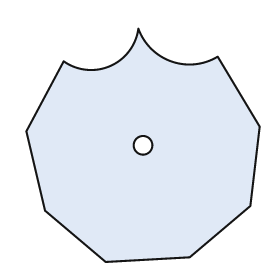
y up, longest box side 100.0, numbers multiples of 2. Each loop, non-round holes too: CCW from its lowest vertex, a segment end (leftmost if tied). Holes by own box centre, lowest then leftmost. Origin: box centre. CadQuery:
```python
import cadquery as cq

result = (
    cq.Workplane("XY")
    .moveTo(-16.0, -50.0)
    .lineTo(20.0, -48.0)
    .lineTo(46.0, -26.0)
    .lineTo(50.0, 8.0)
    .lineTo(32.0, 38.0)
    .threePointArc((12.0, 36.0), (-2.0, 50.0))
    .threePointArc((-14.0, 34.0), (-34.0, 36.0))
    .lineTo(-50.0, 6.0)
    .lineTo(-42.0, -28.0)
    .close()
    .moveTo(0.0, 0.0)
    .circle(4.0)
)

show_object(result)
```